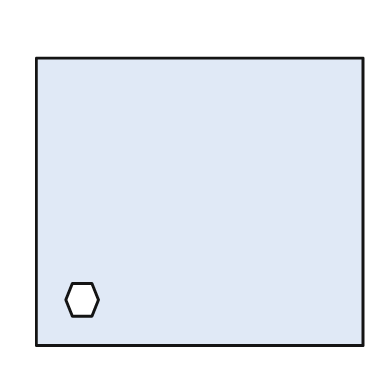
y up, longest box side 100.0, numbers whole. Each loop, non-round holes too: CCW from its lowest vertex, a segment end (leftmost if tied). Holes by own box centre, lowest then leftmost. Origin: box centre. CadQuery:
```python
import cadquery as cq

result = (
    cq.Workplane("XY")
    .moveTo(-50.0, -44.0)
    .lineTo(50.0, -44.0)
    .lineTo(50.0, 44.0)
    .lineTo(-50.0, 44.0)
    .close()
    .moveTo(-39.0, -35.0)
    .lineTo(-33.0, -35.0)
    .lineTo(-31.0, -30.0)
    .lineTo(-33.0, -25.0)
    .lineTo(-39.0, -25.0)
    .lineTo(-41.0, -30.0)
    .close()
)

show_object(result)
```